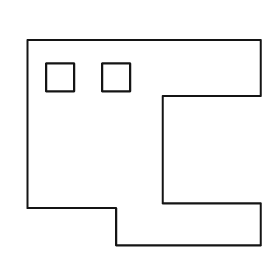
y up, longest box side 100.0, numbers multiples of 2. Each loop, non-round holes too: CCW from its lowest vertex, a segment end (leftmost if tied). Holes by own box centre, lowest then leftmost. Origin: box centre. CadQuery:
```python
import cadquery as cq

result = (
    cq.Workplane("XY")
    .moveTo(-12.0, -44.0)
    .lineTo(50.0, -44.0)
    .lineTo(50.0, -26.0)
    .lineTo(8.0, -26.0)
    .lineTo(8.0, 20.0)
    .lineTo(50.0, 20.0)
    .lineTo(50.0, 44.0)
    .lineTo(-50.0, 44.0)
    .lineTo(-50.0, -28.0)
    .lineTo(-12.0, -28.0)
    .close()
    .moveTo(-42.0, 22.0)
    .lineTo(-30.0, 22.0)
    .lineTo(-30.0, 34.0)
    .lineTo(-42.0, 34.0)
    .close()
    .moveTo(-18.0, 22.0)
    .lineTo(-6.0, 22.0)
    .lineTo(-6.0, 34.0)
    .lineTo(-18.0, 34.0)
    .close()
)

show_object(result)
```